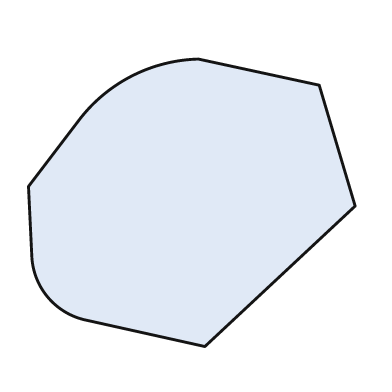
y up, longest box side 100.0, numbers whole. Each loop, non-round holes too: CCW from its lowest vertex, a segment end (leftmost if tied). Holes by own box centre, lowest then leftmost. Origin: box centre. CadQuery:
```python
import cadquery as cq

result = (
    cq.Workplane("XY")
    .moveTo(4.0, -44.0)
    .lineTo(50.0, -1.0)
    .lineTo(39.0, 36.0)
    .lineTo(2.0, 44.0)
    .threePointArc((-18.0, 39.0), (-34.0, 26.0))
    .lineTo(-50.0, 5.0)
    .lineTo(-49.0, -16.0)
    .threePointArc((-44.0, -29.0), (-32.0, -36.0))
    .close()
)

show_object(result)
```